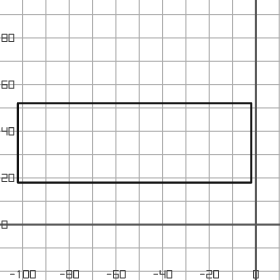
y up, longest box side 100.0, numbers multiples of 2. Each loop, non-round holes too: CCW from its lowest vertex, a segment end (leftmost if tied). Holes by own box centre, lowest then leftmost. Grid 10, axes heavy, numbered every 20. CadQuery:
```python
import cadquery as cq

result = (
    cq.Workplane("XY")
    .moveTo(-102.0, 18.0)
    .lineTo(-2.0, 18.0)
    .lineTo(-2.0, 52.0)
    .lineTo(-102.0, 52.0)
    .close()
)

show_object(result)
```